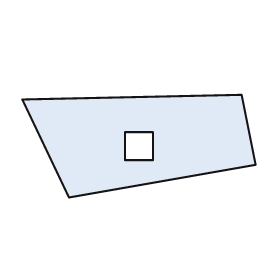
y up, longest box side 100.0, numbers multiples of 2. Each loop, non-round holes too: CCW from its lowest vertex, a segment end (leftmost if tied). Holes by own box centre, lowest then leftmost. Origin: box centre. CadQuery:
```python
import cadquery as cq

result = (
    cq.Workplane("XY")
    .moveTo(-30.0, -22.0)
    .lineTo(50.0, -8.0)
    .lineTo(44.0, 22.0)
    .lineTo(-50.0, 20.0)
    .close()
    .moveTo(-6.0, -6.0)
    .lineTo(6.0, -6.0)
    .lineTo(6.0, 6.0)
    .lineTo(-6.0, 6.0)
    .close()
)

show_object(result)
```